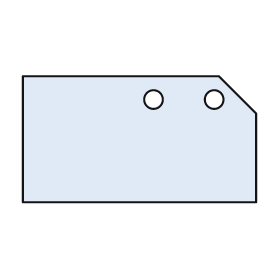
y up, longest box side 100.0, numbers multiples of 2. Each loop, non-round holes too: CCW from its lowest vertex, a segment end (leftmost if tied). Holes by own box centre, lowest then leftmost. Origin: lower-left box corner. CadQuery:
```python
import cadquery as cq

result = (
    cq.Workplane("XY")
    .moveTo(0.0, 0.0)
    .lineTo(100.0, 0.0)
    .lineTo(100.0, 38.0)
    .lineTo(84.0, 54.0)
    .lineTo(0.0, 54.0)
    .close()
    .moveTo(56.0, 44.0)
    .circle(4.0)
    .moveTo(82.0, 44.0)
    .circle(4.0)
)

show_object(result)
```